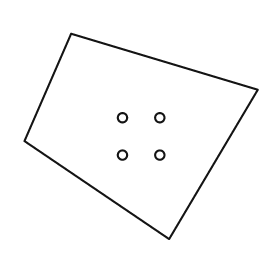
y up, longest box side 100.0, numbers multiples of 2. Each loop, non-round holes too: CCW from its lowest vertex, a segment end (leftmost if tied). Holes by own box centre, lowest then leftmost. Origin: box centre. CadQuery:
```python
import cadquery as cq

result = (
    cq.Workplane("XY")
    .moveTo(12.0, -44.0)
    .lineTo(50.0, 20.0)
    .lineTo(-30.0, 44.0)
    .lineTo(-50.0, -2.0)
    .close()
    .moveTo(-8.0, -8.0)
    .circle(2.0)
    .moveTo(8.0, -8.0)
    .circle(2.0)
    .moveTo(-8.0, 8.0)
    .circle(2.0)
    .moveTo(8.0, 8.0)
    .circle(2.0)
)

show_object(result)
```